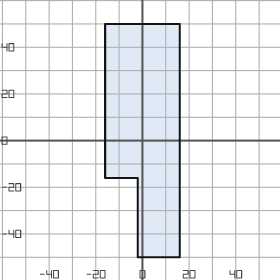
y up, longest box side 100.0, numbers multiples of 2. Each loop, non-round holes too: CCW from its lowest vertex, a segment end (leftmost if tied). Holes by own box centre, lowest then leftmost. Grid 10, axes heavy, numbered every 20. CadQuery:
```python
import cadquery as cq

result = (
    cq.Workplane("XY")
    .moveTo(-2.0, -50.0)
    .lineTo(16.0, -50.0)
    .lineTo(16.0, 50.0)
    .lineTo(-16.0, 50.0)
    .lineTo(-16.0, -16.0)
    .lineTo(-2.0, -16.0)
    .close()
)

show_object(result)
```